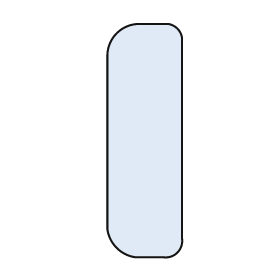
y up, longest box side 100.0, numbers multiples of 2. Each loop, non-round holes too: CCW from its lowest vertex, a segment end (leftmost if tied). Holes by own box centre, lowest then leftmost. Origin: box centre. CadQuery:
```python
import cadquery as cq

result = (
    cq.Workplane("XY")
    .moveTo(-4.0, -50.0)
    .lineTo(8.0, -50.0)
    .threePointArc((14.0, -48.0), (16.0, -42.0))
    .lineTo(16.0, 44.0)
    .threePointArc((14.0, 48.0), (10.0, 50.0))
    .lineTo(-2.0, 50.0)
    .threePointArc((-12.0, 46.0), (-16.0, 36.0))
    .lineTo(-16.0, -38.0)
    .threePointArc((-12.0, -46.0), (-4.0, -50.0))
    .close()
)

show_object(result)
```